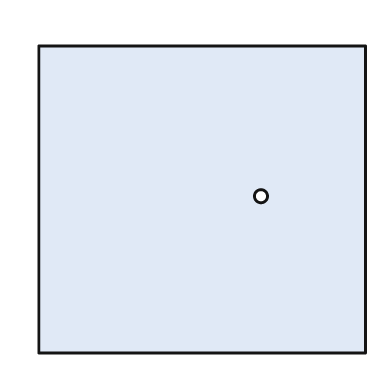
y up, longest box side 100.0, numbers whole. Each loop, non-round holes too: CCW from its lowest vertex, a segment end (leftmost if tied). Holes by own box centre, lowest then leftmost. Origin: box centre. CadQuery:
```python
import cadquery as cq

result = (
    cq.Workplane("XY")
    .moveTo(-50.0, -47.0)
    .lineTo(50.0, -47.0)
    .lineTo(50.0, 47.0)
    .lineTo(-50.0, 47.0)
    .close()
    .moveTo(18.0, 1.0)
    .circle(2.0)
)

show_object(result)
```